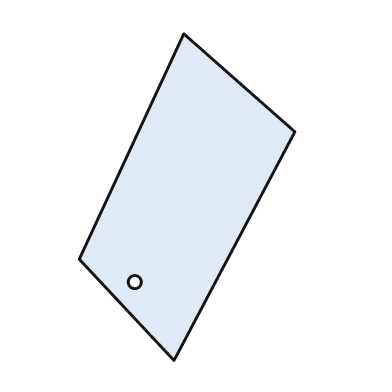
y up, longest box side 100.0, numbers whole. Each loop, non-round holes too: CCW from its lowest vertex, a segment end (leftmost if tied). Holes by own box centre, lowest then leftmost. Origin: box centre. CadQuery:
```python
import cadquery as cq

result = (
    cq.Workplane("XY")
    .moveTo(-4.0, -50.0)
    .lineTo(33.0, 20.0)
    .lineTo(-1.0, 50.0)
    .lineTo(-33.0, -19.0)
    .close()
    .moveTo(-16.0, -26.0)
    .circle(2.0)
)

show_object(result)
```